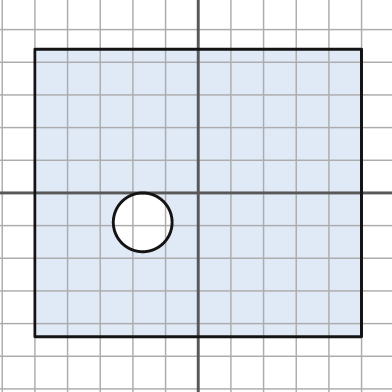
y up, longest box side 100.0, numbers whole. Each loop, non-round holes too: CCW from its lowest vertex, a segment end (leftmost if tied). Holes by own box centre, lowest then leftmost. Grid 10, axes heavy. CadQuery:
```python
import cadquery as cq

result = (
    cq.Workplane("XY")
    .moveTo(-50.0, -44.0)
    .lineTo(50.0, -44.0)
    .lineTo(50.0, 44.0)
    .lineTo(-50.0, 44.0)
    .close()
    .moveTo(-17.0, -9.0)
    .circle(9.0)
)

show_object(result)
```